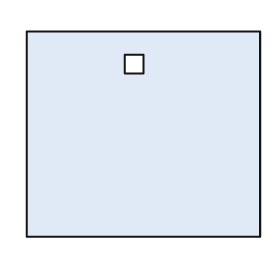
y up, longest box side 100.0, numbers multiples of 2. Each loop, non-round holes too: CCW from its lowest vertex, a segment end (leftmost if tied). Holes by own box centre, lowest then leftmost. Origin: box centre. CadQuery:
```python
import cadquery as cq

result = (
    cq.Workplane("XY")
    .moveTo(-50.0, -44.0)
    .lineTo(50.0, -44.0)
    .lineTo(50.0, 44.0)
    .lineTo(-50.0, 44.0)
    .close()
    .moveTo(-8.0, 26.0)
    .lineTo(0.0, 26.0)
    .lineTo(0.0, 34.0)
    .lineTo(-8.0, 34.0)
    .close()
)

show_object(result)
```